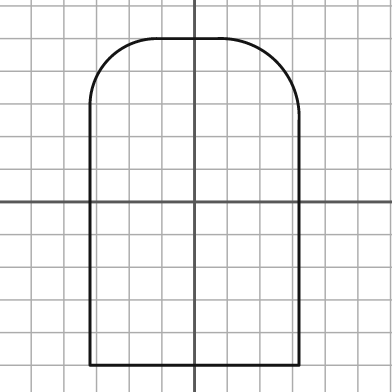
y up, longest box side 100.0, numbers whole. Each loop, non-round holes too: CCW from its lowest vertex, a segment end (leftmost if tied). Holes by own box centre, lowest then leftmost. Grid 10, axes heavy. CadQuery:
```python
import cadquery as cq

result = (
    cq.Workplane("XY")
    .moveTo(-32.0, -50.0)
    .lineTo(32.0, -50.0)
    .lineTo(32.0, 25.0)
    .threePointArc((25.0, 43.0), (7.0, 50.0))
    .lineTo(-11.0, 50.0)
    .threePointArc((-26.0, 44.0), (-32.0, 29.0))
    .close()
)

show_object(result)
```